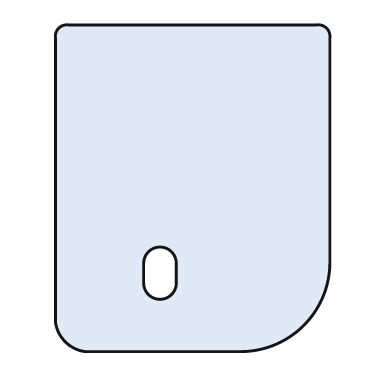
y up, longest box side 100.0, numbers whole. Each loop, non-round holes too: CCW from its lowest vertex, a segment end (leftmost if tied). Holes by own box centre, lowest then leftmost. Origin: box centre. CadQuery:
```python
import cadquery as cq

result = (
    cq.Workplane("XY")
    .moveTo(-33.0, -50.0)
    .lineTo(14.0, -50.0)
    .threePointArc((34.0, -42.0), (42.0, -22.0))
    .lineTo(42.0, 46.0)
    .threePointArc((41.0, 49.0), (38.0, 50.0))
    .lineTo(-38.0, 50.0)
    .threePointArc((-41.0, 49.0), (-42.0, 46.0))
    .lineTo(-42.0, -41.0)
    .threePointArc((-39.0, -47.0), (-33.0, -50.0))
    .close()
    .moveTo(-15.0, -29.0)
    .threePointArc((-10.0, -34.0), (-5.0, -29.0))
    .lineTo(-5.0, -23.0)
    .threePointArc((-10.0, -18.0), (-15.0, -23.0))
    .close()
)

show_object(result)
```